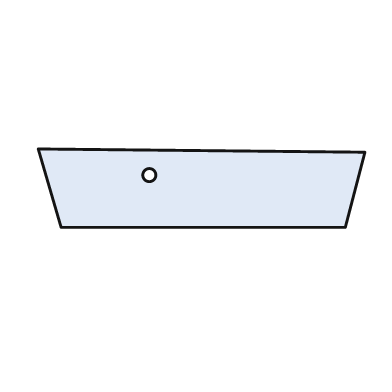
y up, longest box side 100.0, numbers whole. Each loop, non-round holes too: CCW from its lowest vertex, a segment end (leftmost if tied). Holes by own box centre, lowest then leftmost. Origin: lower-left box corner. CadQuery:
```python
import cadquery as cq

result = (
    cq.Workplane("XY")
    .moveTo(7.0, 0.0)
    .lineTo(94.0, 0.0)
    .lineTo(100.0, 23.0)
    .lineTo(0.0, 24.0)
    .close()
    .moveTo(34.0, 16.0)
    .circle(2.0)
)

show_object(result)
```